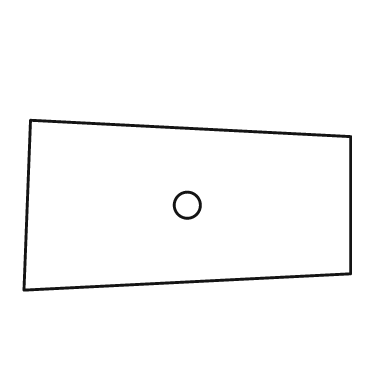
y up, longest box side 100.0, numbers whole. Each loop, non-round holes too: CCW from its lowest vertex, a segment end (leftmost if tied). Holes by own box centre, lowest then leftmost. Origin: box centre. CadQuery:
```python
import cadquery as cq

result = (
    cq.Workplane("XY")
    .moveTo(-50.0, -26.0)
    .lineTo(50.0, -21.0)
    .lineTo(50.0, 21.0)
    .lineTo(-48.0, 26.0)
    .close()
    .moveTo(0.0, 0.0)
    .circle(4.0)
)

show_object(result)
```